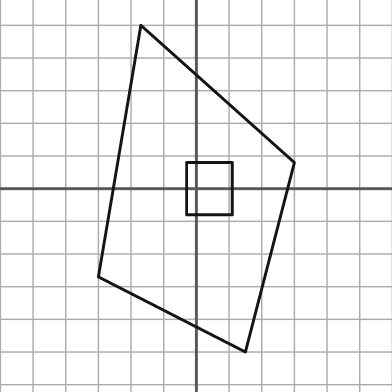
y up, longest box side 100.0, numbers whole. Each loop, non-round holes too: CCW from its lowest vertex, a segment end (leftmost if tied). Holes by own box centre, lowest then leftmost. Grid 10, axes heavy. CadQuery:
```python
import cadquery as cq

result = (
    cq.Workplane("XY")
    .moveTo(15.0, -50.0)
    .lineTo(30.0, 8.0)
    .lineTo(-17.0, 50.0)
    .lineTo(-30.0, -27.0)
    .close()
    .moveTo(-3.0, -8.0)
    .lineTo(11.0, -8.0)
    .lineTo(11.0, 8.0)
    .lineTo(-3.0, 8.0)
    .close()
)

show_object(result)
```